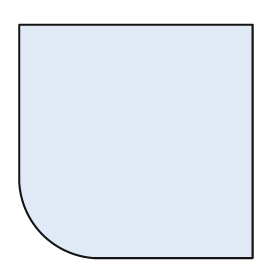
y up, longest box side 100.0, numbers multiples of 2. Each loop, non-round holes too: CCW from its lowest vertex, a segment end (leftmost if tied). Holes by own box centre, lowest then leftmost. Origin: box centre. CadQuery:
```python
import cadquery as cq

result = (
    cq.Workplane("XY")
    .moveTo(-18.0, -50.0)
    .lineTo(50.0, -50.0)
    .lineTo(50.0, 50.0)
    .lineTo(-50.0, 50.0)
    .lineTo(-50.0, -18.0)
    .threePointArc((-40.0, -40.0), (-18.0, -50.0))
    .close()
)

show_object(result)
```